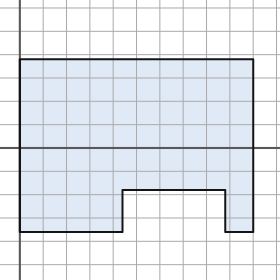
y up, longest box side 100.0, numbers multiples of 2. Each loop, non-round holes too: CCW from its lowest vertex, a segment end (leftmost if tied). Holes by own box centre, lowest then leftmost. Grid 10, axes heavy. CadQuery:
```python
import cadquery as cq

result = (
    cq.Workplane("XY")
    .moveTo(0.0, -36.0)
    .lineTo(44.0, -36.0)
    .lineTo(44.0, -18.0)
    .lineTo(88.0, -18.0)
    .lineTo(88.0, -36.0)
    .lineTo(100.0, -36.0)
    .lineTo(100.0, 38.0)
    .lineTo(0.0, 38.0)
    .close()
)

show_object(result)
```